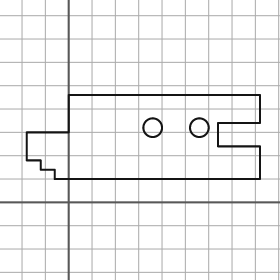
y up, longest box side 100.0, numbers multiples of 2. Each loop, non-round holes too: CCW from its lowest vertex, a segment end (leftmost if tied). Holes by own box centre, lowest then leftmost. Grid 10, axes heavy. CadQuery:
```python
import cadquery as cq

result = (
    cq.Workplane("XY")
    .moveTo(-6.0, 10.0)
    .lineTo(82.0, 10.0)
    .lineTo(82.0, 24.0)
    .lineTo(64.0, 24.0)
    .lineTo(64.0, 34.0)
    .lineTo(82.0, 34.0)
    .lineTo(82.0, 46.0)
    .lineTo(0.0, 46.0)
    .lineTo(0.0, 30.0)
    .lineTo(-18.0, 30.0)
    .lineTo(-18.0, 18.0)
    .lineTo(-12.0, 18.0)
    .lineTo(-12.0, 14.0)
    .lineTo(-6.0, 14.0)
    .close()
    .moveTo(36.0, 32.0)
    .circle(4.0)
    .moveTo(56.0, 32.0)
    .circle(4.0)
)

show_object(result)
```